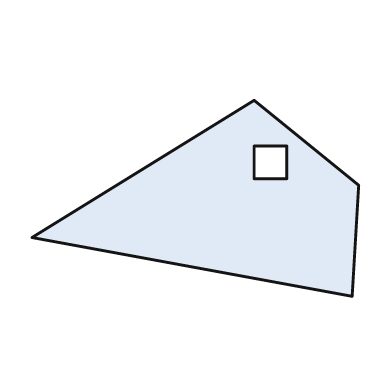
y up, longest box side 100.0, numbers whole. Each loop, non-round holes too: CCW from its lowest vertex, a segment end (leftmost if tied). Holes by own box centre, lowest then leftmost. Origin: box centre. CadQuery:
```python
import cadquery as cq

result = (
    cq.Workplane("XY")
    .moveTo(48.0, -30.0)
    .lineTo(50.0, 4.0)
    .lineTo(18.0, 30.0)
    .lineTo(-50.0, -12.0)
    .close()
    .moveTo(18.0, 6.0)
    .lineTo(28.0, 6.0)
    .lineTo(28.0, 16.0)
    .lineTo(18.0, 16.0)
    .close()
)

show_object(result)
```